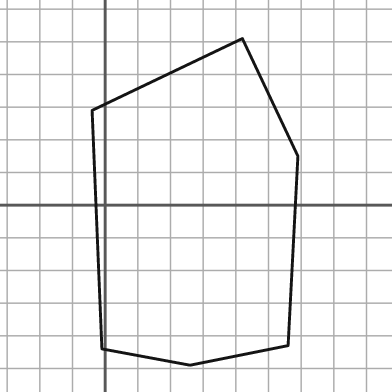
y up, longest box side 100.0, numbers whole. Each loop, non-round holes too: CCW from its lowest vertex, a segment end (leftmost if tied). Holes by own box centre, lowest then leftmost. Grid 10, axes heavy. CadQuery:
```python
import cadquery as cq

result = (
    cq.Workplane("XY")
    .moveTo(26.0, -49.0)
    .lineTo(56.0, -43.0)
    .lineTo(59.0, 15.0)
    .lineTo(42.0, 51.0)
    .lineTo(-4.0, 29.0)
    .lineTo(-1.0, -44.0)
    .close()
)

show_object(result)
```